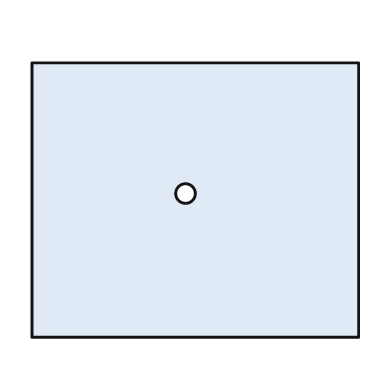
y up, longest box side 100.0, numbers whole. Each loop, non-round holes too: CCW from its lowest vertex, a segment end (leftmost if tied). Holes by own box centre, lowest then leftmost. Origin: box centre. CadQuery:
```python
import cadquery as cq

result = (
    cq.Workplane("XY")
    .moveTo(-50.0, -42.0)
    .lineTo(50.0, -42.0)
    .lineTo(50.0, 42.0)
    .lineTo(-50.0, 42.0)
    .close()
    .moveTo(-3.0, 2.0)
    .circle(3.0)
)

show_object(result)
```